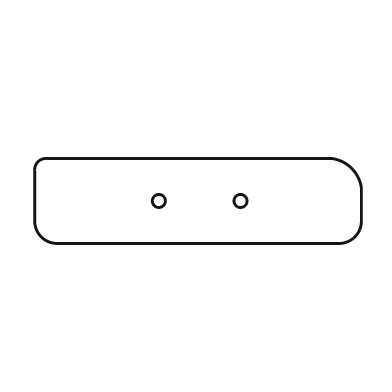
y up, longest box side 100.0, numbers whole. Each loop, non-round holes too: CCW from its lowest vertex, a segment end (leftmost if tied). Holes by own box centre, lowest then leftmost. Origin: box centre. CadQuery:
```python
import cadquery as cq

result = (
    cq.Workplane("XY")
    .moveTo(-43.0, -13.0)
    .lineTo(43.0, -13.0)
    .threePointArc((48.0, -11.0), (50.0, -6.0))
    .lineTo(50.0, 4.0)
    .threePointArc((47.0, 10.0), (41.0, 13.0))
    .lineTo(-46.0, 13.0)
    .threePointArc((-49.0, 12.0), (-50.0, 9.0))
    .lineTo(-50.0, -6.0)
    .threePointArc((-48.0, -11.0), (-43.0, -13.0))
    .close()
    .moveTo(-12.0, 0.0)
    .circle(2.0)
    .moveTo(13.0, 0.0)
    .circle(2.0)
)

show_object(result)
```